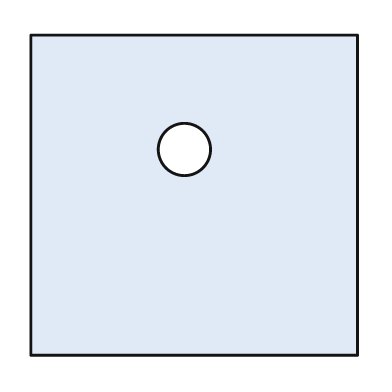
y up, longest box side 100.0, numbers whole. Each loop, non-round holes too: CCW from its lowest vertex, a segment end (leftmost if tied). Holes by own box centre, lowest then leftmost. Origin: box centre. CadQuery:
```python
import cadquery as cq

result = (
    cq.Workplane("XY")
    .moveTo(-50.0, -49.0)
    .lineTo(50.0, -49.0)
    .lineTo(50.0, 49.0)
    .lineTo(-50.0, 49.0)
    .close()
    .moveTo(-3.0, 14.0)
    .circle(8.0)
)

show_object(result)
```